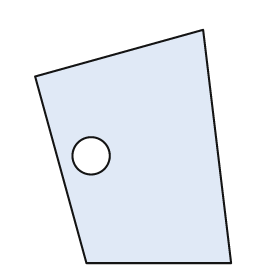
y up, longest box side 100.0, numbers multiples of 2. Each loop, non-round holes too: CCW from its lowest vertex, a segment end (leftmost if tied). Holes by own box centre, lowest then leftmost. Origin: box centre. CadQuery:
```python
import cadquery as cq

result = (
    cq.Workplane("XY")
    .moveTo(-20.0, -50.0)
    .lineTo(42.0, -50.0)
    .lineTo(30.0, 50.0)
    .lineTo(-42.0, 30.0)
    .close()
    .moveTo(-18.0, -4.0)
    .circle(8.0)
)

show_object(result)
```